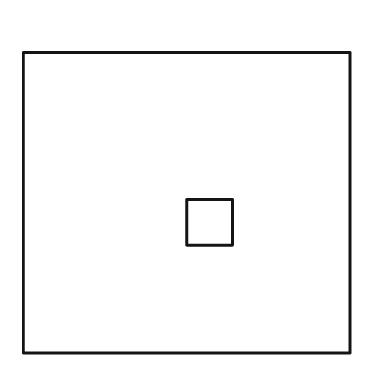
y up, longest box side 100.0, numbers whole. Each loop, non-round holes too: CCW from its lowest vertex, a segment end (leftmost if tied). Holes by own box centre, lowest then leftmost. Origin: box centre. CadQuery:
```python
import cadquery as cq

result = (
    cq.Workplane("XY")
    .moveTo(-50.0, -46.0)
    .lineTo(50.0, -46.0)
    .lineTo(50.0, 46.0)
    .lineTo(-50.0, 46.0)
    .close()
    .moveTo(0.0, -13.0)
    .lineTo(14.0, -13.0)
    .lineTo(14.0, 1.0)
    .lineTo(0.0, 1.0)
    .close()
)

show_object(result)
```